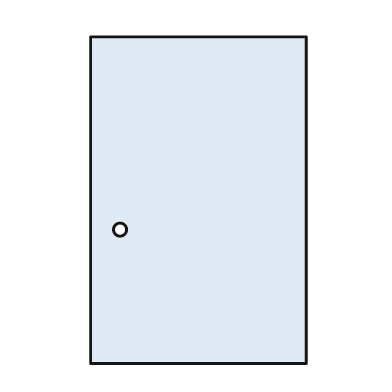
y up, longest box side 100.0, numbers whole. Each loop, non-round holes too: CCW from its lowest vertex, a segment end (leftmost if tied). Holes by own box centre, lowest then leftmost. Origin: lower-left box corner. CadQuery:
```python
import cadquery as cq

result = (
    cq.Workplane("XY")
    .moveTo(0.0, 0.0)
    .lineTo(66.0, 0.0)
    .lineTo(66.0, 100.0)
    .lineTo(0.0, 100.0)
    .close()
    .moveTo(9.0, 41.0)
    .circle(2.0)
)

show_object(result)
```